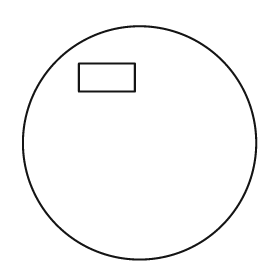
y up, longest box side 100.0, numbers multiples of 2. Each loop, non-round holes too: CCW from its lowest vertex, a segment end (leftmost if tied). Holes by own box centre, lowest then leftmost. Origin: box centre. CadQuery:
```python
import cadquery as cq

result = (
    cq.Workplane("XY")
    .moveTo(0.0, 0.0)
    .circle(50.0)
    .moveTo(-26.0, 22.0)
    .lineTo(-2.0, 22.0)
    .lineTo(-2.0, 34.0)
    .lineTo(-26.0, 34.0)
    .close()
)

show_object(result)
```